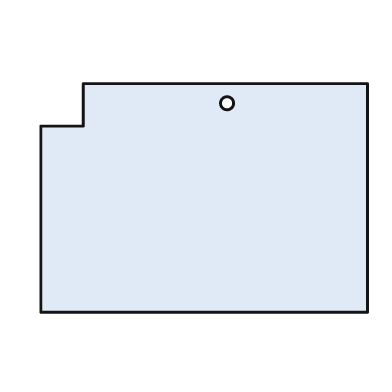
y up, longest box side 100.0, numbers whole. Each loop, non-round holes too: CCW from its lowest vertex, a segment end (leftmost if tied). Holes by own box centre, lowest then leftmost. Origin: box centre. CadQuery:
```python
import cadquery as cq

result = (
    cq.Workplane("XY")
    .moveTo(-50.0, -35.0)
    .lineTo(50.0, -35.0)
    .lineTo(50.0, 35.0)
    .lineTo(-37.0, 35.0)
    .lineTo(-37.0, 22.0)
    .lineTo(-50.0, 22.0)
    .close()
    .moveTo(7.0, 29.0)
    .circle(2.0)
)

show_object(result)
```